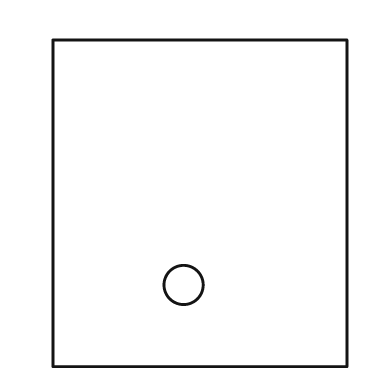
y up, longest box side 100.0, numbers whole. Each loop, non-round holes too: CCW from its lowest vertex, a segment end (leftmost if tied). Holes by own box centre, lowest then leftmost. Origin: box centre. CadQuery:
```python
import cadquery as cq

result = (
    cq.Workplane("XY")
    .moveTo(-45.0, -50.0)
    .lineTo(45.0, -50.0)
    .lineTo(45.0, 50.0)
    .lineTo(-45.0, 50.0)
    .close()
    .moveTo(-5.0, -25.0)
    .circle(6.0)
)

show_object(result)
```